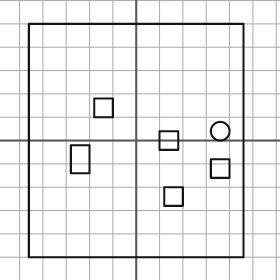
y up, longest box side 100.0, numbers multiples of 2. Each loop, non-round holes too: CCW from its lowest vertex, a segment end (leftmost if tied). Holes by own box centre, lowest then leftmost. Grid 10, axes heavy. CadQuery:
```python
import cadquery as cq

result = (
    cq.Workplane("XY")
    .moveTo(-46.0, -50.0)
    .lineTo(46.0, -50.0)
    .lineTo(46.0, 50.0)
    .lineTo(-46.0, 50.0)
    .close()
    .moveTo(12.0, -28.0)
    .lineTo(20.0, -28.0)
    .lineTo(20.0, -20.0)
    .lineTo(12.0, -20.0)
    .close()
    .moveTo(32.0, -16.0)
    .lineTo(40.0, -16.0)
    .lineTo(40.0, -8.0)
    .lineTo(32.0, -8.0)
    .close()
    .moveTo(-28.0, -14.0)
    .lineTo(-20.0, -14.0)
    .lineTo(-20.0, -2.0)
    .lineTo(-28.0, -2.0)
    .close()
    .moveTo(10.0, -4.0)
    .lineTo(18.0, -4.0)
    .lineTo(18.0, 4.0)
    .lineTo(10.0, 4.0)
    .close()
    .moveTo(36.0, 4.0)
    .circle(4.0)
    .moveTo(-18.0, 10.0)
    .lineTo(-10.0, 10.0)
    .lineTo(-10.0, 18.0)
    .lineTo(-18.0, 18.0)
    .close()
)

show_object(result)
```